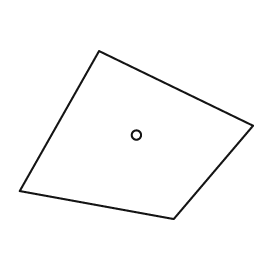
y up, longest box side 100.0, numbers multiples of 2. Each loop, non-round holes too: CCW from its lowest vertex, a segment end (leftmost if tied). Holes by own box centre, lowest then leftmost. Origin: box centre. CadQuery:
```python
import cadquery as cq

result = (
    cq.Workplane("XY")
    .moveTo(16.0, -36.0)
    .lineTo(50.0, 4.0)
    .lineTo(-16.0, 36.0)
    .lineTo(-50.0, -24.0)
    .close()
    .moveTo(0.0, 0.0)
    .circle(2.0)
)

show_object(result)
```